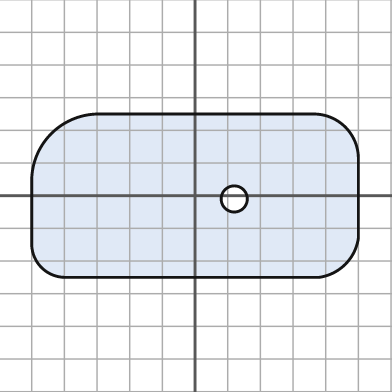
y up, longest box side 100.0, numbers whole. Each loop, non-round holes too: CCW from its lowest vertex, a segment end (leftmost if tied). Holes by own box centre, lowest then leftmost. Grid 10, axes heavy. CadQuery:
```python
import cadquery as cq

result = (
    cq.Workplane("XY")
    .moveTo(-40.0, -25.0)
    .lineTo(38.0, -25.0)
    .threePointArc((46.0, -21.0), (50.0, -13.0))
    .lineTo(50.0, 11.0)
    .threePointArc((46.0, 21.0), (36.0, 25.0))
    .lineTo(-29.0, 25.0)
    .threePointArc((-44.0, 19.0), (-50.0, 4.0))
    .lineTo(-50.0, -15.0)
    .threePointArc((-47.0, -22.0), (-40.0, -25.0))
    .close()
    .moveTo(12.0, -1.0)
    .circle(4.0)
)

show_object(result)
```